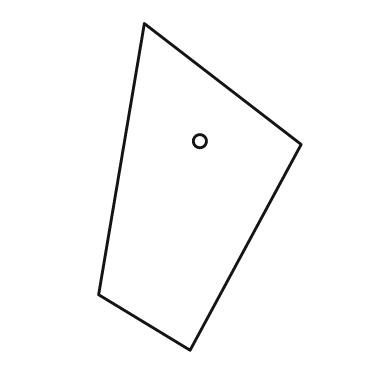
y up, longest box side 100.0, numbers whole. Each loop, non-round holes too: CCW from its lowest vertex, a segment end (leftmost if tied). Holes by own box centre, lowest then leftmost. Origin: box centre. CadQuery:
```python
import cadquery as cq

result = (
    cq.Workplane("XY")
    .moveTo(-3.0, -50.0)
    .lineTo(31.0, 13.0)
    .lineTo(-17.0, 50.0)
    .lineTo(-31.0, -33.0)
    .close()
    .moveTo(0.0, 14.0)
    .circle(2.0)
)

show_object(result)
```